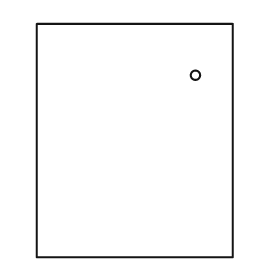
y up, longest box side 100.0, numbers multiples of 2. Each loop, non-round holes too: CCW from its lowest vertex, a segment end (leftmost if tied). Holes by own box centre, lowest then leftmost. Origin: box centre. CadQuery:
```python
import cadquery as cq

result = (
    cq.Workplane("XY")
    .moveTo(-42.0, -50.0)
    .lineTo(42.0, -50.0)
    .lineTo(42.0, 50.0)
    .lineTo(-42.0, 50.0)
    .close()
    .moveTo(26.0, 28.0)
    .circle(2.0)
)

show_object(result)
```